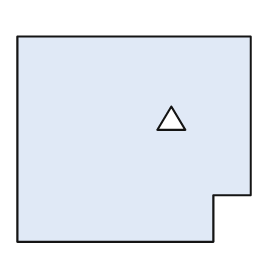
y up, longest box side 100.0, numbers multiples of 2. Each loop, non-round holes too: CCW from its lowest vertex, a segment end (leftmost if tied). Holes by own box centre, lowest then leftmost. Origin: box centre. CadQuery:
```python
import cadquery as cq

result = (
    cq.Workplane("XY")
    .moveTo(-50.0, -44.0)
    .lineTo(34.0, -44.0)
    .lineTo(34.0, -24.0)
    .lineTo(50.0, -24.0)
    .lineTo(50.0, 44.0)
    .lineTo(-50.0, 44.0)
    .close()
    .moveTo(10.0, 4.0)
    .lineTo(22.0, 4.0)
    .lineTo(16.0, 14.0)
    .close()
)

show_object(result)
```